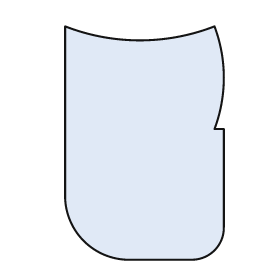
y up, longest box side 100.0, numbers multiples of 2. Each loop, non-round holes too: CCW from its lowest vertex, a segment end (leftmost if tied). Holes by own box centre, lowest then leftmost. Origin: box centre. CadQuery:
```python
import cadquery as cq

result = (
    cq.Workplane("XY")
    .moveTo(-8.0, -50.0)
    .lineTo(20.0, -50.0)
    .threePointArc((30.0, -46.0), (34.0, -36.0))
    .lineTo(34.0, 6.0)
    .lineTo(30.0, 6.0)
    .threePointArc((34.0, 28.0), (30.0, 50.0))
    .threePointArc((-2.0, 44.0), (-34.0, 50.0))
    .lineTo(-34.0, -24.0)
    .threePointArc((-26.0, -42.0), (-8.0, -50.0))
    .close()
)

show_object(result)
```